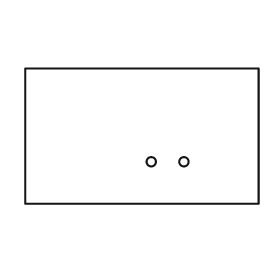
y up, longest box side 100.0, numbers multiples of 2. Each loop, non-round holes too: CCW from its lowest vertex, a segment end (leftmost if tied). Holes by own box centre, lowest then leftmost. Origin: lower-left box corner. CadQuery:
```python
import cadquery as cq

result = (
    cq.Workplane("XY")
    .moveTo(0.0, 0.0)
    .lineTo(100.0, 0.0)
    .lineTo(100.0, 58.0)
    .lineTo(0.0, 58.0)
    .close()
    .moveTo(54.0, 18.0)
    .circle(2.0)
    .moveTo(68.0, 18.0)
    .circle(2.0)
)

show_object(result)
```